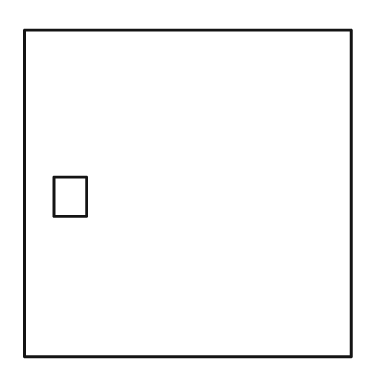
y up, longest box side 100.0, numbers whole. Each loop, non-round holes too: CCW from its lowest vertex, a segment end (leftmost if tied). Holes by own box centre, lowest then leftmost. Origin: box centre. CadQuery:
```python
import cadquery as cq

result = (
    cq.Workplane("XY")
    .moveTo(-50.0, -50.0)
    .lineTo(50.0, -50.0)
    .lineTo(50.0, 50.0)
    .lineTo(-50.0, 50.0)
    .close()
    .moveTo(-41.0, -7.0)
    .lineTo(-31.0, -7.0)
    .lineTo(-31.0, 5.0)
    .lineTo(-41.0, 5.0)
    .close()
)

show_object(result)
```